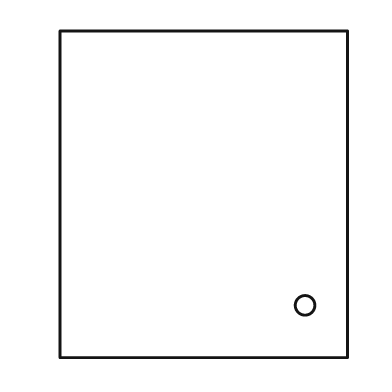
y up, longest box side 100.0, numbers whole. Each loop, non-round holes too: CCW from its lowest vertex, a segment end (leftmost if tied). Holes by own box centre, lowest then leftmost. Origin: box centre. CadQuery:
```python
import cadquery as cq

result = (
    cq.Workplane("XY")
    .moveTo(-44.0, -50.0)
    .lineTo(44.0, -50.0)
    .lineTo(44.0, 50.0)
    .lineTo(-44.0, 50.0)
    .close()
    .moveTo(31.0, -34.0)
    .circle(3.0)
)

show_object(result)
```